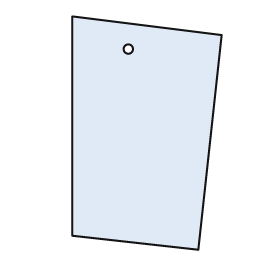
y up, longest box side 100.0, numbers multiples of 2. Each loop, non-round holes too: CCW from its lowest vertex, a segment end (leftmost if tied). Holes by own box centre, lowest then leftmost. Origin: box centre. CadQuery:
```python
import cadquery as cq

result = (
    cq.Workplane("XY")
    .moveTo(22.0, -50.0)
    .lineTo(32.0, 42.0)
    .lineTo(-32.0, 50.0)
    .lineTo(-32.0, -44.0)
    .close()
    .moveTo(-8.0, 36.0)
    .circle(2.0)
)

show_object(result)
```